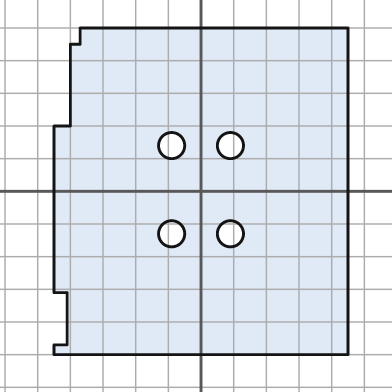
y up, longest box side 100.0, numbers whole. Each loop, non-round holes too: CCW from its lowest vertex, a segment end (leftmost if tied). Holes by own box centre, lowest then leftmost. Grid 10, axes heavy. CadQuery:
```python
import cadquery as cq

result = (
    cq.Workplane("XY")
    .moveTo(-45.0, -50.0)
    .lineTo(45.0, -50.0)
    .lineTo(45.0, 50.0)
    .lineTo(-37.0, 50.0)
    .lineTo(-37.0, 45.0)
    .lineTo(-40.0, 45.0)
    .lineTo(-40.0, 20.0)
    .lineTo(-45.0, 20.0)
    .lineTo(-45.0, -31.0)
    .lineTo(-41.0, -31.0)
    .lineTo(-41.0, -47.0)
    .lineTo(-45.0, -47.0)
    .close()
    .moveTo(-9.0, -13.0)
    .circle(4.0)
    .moveTo(9.0, -13.0)
    .circle(4.0)
    .moveTo(-9.0, 14.0)
    .circle(4.0)
    .moveTo(9.0, 14.0)
    .circle(4.0)
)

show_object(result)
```